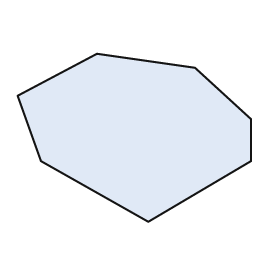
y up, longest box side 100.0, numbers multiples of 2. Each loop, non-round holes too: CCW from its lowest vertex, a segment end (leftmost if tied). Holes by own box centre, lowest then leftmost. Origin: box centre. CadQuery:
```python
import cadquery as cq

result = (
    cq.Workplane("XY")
    .moveTo(6.0, -36.0)
    .lineTo(50.0, -10.0)
    .lineTo(50.0, 8.0)
    .lineTo(26.0, 30.0)
    .lineTo(-16.0, 36.0)
    .lineTo(-50.0, 18.0)
    .lineTo(-40.0, -10.0)
    .close()
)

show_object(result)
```